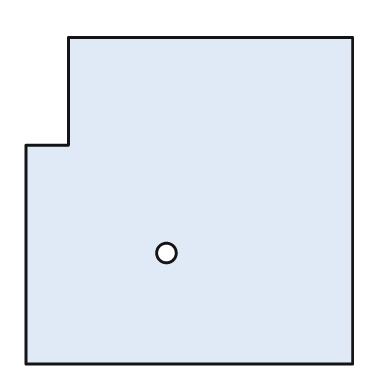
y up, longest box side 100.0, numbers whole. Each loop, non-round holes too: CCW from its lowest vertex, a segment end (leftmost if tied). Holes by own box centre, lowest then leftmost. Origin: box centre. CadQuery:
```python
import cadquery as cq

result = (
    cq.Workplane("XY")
    .moveTo(-50.0, -50.0)
    .lineTo(50.0, -50.0)
    .lineTo(50.0, 50.0)
    .lineTo(-37.0, 50.0)
    .lineTo(-37.0, 17.0)
    .lineTo(-50.0, 17.0)
    .close()
    .moveTo(-7.0, -16.0)
    .circle(3.0)
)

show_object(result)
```